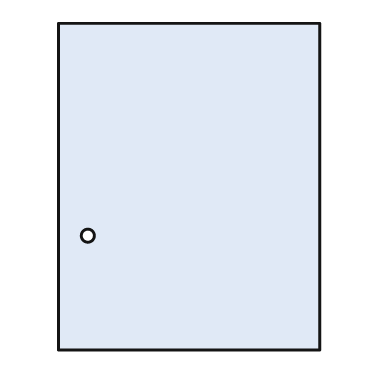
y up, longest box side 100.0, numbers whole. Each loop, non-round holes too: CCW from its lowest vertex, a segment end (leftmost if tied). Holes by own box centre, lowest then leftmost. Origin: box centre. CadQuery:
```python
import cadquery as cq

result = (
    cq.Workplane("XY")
    .moveTo(-40.0, -50.0)
    .lineTo(40.0, -50.0)
    .lineTo(40.0, 50.0)
    .lineTo(-40.0, 50.0)
    .close()
    .moveTo(-31.0, -15.0)
    .circle(2.0)
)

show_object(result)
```